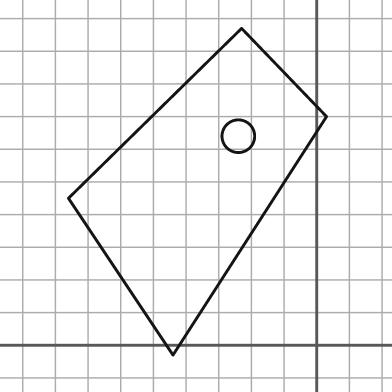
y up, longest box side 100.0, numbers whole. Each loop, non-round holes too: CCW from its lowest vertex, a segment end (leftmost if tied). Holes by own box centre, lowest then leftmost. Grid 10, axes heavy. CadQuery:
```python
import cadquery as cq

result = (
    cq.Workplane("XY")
    .moveTo(-44.0, -3.0)
    .lineTo(3.0, 70.0)
    .lineTo(-23.0, 97.0)
    .lineTo(-76.0, 45.0)
    .close()
    .moveTo(-24.0, 64.0)
    .circle(5.0)
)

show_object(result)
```